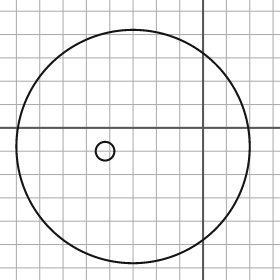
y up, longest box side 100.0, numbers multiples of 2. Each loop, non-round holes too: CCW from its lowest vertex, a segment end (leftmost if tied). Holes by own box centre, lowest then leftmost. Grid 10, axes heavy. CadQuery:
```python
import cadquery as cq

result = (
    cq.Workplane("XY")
    .moveTo(-30.0, -8.0)
    .circle(50.0)
    .moveTo(-42.0, -10.0)
    .circle(4.0)
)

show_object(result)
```